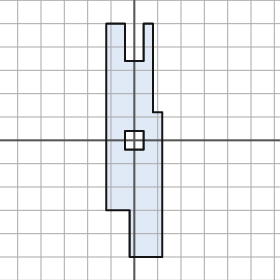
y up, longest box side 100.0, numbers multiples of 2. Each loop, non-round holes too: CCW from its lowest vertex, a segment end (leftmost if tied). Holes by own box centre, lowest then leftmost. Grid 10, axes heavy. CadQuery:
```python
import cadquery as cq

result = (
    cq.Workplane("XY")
    .moveTo(-2.0, -50.0)
    .lineTo(12.0, -50.0)
    .lineTo(12.0, 12.0)
    .lineTo(8.0, 12.0)
    .lineTo(8.0, 50.0)
    .lineTo(4.0, 50.0)
    .lineTo(4.0, 34.0)
    .lineTo(-4.0, 34.0)
    .lineTo(-4.0, 50.0)
    .lineTo(-12.0, 50.0)
    .lineTo(-12.0, -30.0)
    .lineTo(-2.0, -30.0)
    .close()
    .moveTo(-4.0, -4.0)
    .lineTo(4.0, -4.0)
    .lineTo(4.0, 4.0)
    .lineTo(-4.0, 4.0)
    .close()
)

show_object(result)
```